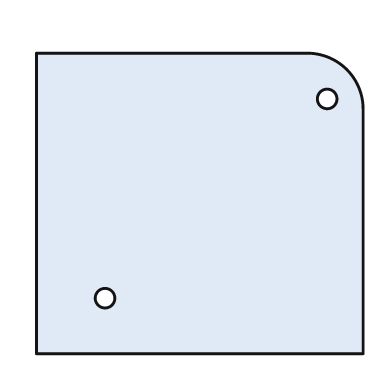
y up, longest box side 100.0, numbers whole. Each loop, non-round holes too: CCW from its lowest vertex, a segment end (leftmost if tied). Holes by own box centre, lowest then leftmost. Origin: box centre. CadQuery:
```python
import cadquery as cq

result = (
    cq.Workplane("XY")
    .moveTo(-50.0, -46.0)
    .lineTo(50.0, -46.0)
    .lineTo(50.0, 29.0)
    .threePointArc((45.0, 41.0), (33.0, 46.0))
    .lineTo(-50.0, 46.0)
    .close()
    .moveTo(-29.0, -29.0)
    .circle(3.0)
    .moveTo(39.0, 32.0)
    .circle(3.0)
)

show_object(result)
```